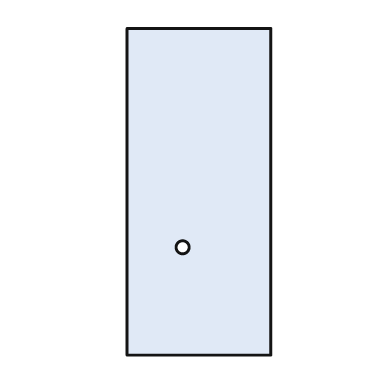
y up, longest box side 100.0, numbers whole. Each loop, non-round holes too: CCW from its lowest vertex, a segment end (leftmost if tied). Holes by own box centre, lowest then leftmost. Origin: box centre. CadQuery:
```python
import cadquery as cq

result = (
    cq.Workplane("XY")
    .moveTo(-22.0, -50.0)
    .lineTo(22.0, -50.0)
    .lineTo(22.0, 50.0)
    .lineTo(-22.0, 50.0)
    .close()
    .moveTo(-5.0, -17.0)
    .circle(2.0)
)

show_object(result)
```